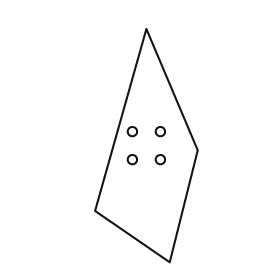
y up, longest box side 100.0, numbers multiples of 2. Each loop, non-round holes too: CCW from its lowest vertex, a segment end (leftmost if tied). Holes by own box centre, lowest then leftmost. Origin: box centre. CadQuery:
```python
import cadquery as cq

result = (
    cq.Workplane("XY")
    .moveTo(10.0, -50.0)
    .lineTo(22.0, -2.0)
    .lineTo(0.0, 50.0)
    .lineTo(-22.0, -28.0)
    .close()
    .moveTo(-6.0, -6.0)
    .circle(2.0)
    .moveTo(6.0, -6.0)
    .circle(2.0)
    .moveTo(-6.0, 6.0)
    .circle(2.0)
    .moveTo(6.0, 6.0)
    .circle(2.0)
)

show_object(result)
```